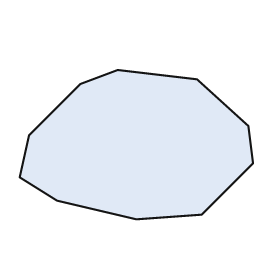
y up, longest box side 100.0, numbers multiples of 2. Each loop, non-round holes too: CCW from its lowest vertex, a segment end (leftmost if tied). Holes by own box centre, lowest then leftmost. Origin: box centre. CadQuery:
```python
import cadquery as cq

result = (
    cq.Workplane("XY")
    .moveTo(0.0, -32.0)
    .lineTo(28.0, -30.0)
    .lineTo(50.0, -8.0)
    .lineTo(48.0, 8.0)
    .lineTo(26.0, 28.0)
    .lineTo(-8.0, 32.0)
    .lineTo(-24.0, 26.0)
    .lineTo(-46.0, 4.0)
    .lineTo(-50.0, -14.0)
    .lineTo(-34.0, -24.0)
    .close()
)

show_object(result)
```